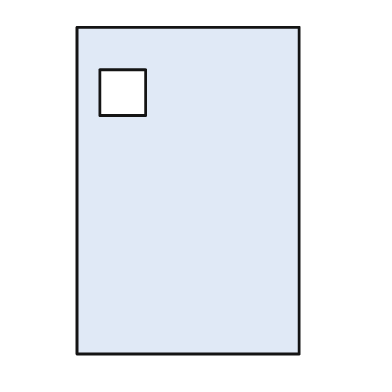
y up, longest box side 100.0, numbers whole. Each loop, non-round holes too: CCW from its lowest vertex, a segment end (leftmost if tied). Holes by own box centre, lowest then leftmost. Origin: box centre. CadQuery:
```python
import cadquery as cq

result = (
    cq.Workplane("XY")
    .moveTo(-34.0, -50.0)
    .lineTo(34.0, -50.0)
    .lineTo(34.0, 50.0)
    .lineTo(-34.0, 50.0)
    .close()
    .moveTo(-27.0, 23.0)
    .lineTo(-13.0, 23.0)
    .lineTo(-13.0, 37.0)
    .lineTo(-27.0, 37.0)
    .close()
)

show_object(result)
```